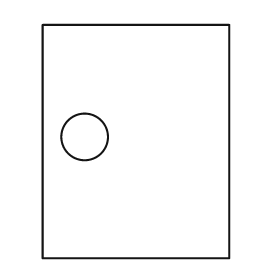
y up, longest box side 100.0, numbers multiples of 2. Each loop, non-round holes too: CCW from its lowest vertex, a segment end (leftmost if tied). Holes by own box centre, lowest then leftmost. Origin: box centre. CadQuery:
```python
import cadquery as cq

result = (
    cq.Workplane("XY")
    .moveTo(-40.0, -50.0)
    .lineTo(40.0, -50.0)
    .lineTo(40.0, 50.0)
    .lineTo(-40.0, 50.0)
    .close()
    .moveTo(-22.0, 2.0)
    .circle(10.0)
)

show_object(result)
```